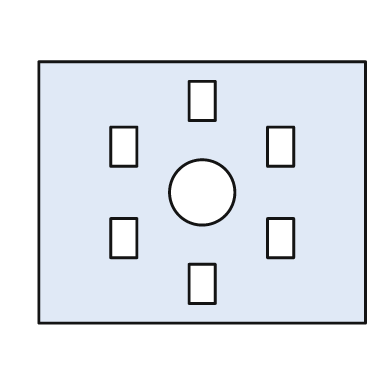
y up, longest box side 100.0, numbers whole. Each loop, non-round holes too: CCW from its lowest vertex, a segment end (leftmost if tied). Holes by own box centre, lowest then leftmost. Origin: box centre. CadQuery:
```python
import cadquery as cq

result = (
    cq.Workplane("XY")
    .moveTo(-50.0, -40.0)
    .lineTo(50.0, -40.0)
    .lineTo(50.0, 40.0)
    .lineTo(-50.0, 40.0)
    .close()
    .moveTo(-4.0, -34.0)
    .lineTo(4.0, -34.0)
    .lineTo(4.0, -22.0)
    .lineTo(-4.0, -22.0)
    .close()
    .moveTo(-28.0, -20.0)
    .lineTo(-20.0, -20.0)
    .lineTo(-20.0, -8.0)
    .lineTo(-28.0, -8.0)
    .close()
    .moveTo(20.0, -20.0)
    .lineTo(28.0, -20.0)
    .lineTo(28.0, -8.0)
    .lineTo(20.0, -8.0)
    .close()
    .moveTo(0.0, 0.0)
    .circle(10.0)
    .moveTo(-28.0, 8.0)
    .lineTo(-20.0, 8.0)
    .lineTo(-20.0, 20.0)
    .lineTo(-28.0, 20.0)
    .close()
    .moveTo(20.0, 8.0)
    .lineTo(28.0, 8.0)
    .lineTo(28.0, 20.0)
    .lineTo(20.0, 20.0)
    .close()
    .moveTo(-4.0, 22.0)
    .lineTo(4.0, 22.0)
    .lineTo(4.0, 34.0)
    .lineTo(-4.0, 34.0)
    .close()
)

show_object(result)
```